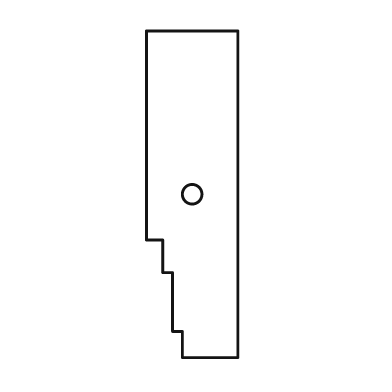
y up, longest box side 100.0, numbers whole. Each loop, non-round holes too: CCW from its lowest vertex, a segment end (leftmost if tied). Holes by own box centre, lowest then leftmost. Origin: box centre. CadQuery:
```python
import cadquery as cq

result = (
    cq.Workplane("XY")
    .moveTo(-3.0, -50.0)
    .lineTo(14.0, -50.0)
    .lineTo(14.0, 50.0)
    .lineTo(-14.0, 50.0)
    .lineTo(-14.0, -14.0)
    .lineTo(-9.0, -14.0)
    .lineTo(-9.0, -24.0)
    .lineTo(-6.0, -24.0)
    .lineTo(-6.0, -42.0)
    .lineTo(-3.0, -42.0)
    .close()
    .moveTo(0.0, 0.0)
    .circle(3.0)
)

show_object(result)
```